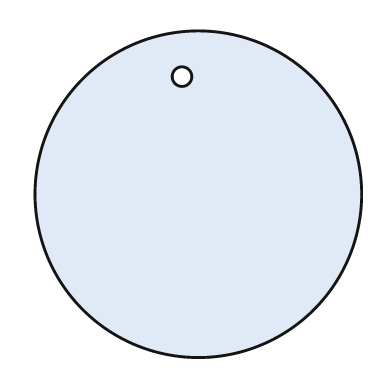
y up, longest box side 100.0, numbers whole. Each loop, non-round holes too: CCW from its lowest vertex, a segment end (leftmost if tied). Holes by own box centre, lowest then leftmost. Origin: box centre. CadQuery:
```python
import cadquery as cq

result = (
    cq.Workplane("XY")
    .moveTo(0.0, 0.0)
    .circle(50.0)
    .moveTo(-5.0, 36.0)
    .circle(3.0)
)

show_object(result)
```